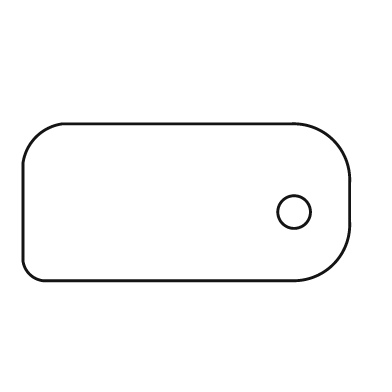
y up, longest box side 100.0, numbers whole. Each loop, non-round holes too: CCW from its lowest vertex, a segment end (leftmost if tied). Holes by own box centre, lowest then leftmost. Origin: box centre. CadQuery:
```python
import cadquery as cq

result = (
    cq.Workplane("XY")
    .moveTo(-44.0, -24.0)
    .lineTo(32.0, -24.0)
    .threePointArc((45.0, -19.0), (50.0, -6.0))
    .lineTo(50.0, 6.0)
    .threePointArc((45.0, 19.0), (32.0, 24.0))
    .lineTo(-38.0, 24.0)
    .threePointArc((-46.0, 20.0), (-50.0, 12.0))
    .lineTo(-50.0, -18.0)
    .threePointArc((-48.0, -22.0), (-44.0, -24.0))
    .close()
    .moveTo(33.0, -3.0)
    .circle(5.0)
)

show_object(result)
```